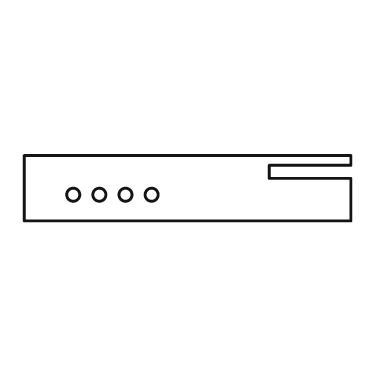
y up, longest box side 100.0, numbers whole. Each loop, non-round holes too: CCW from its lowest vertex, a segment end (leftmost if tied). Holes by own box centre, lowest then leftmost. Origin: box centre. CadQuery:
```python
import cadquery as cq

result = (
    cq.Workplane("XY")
    .moveTo(-50.0, -10.0)
    .lineTo(50.0, -10.0)
    .lineTo(50.0, 3.0)
    .lineTo(25.0, 3.0)
    .lineTo(25.0, 7.0)
    .lineTo(50.0, 7.0)
    .lineTo(50.0, 10.0)
    .lineTo(-50.0, 10.0)
    .close()
    .moveTo(-35.0, -2.0)
    .circle(2.0)
    .moveTo(-27.0, -2.0)
    .circle(2.0)
    .moveTo(-19.0, -2.0)
    .circle(2.0)
    .moveTo(-11.0, -2.0)
    .circle(2.0)
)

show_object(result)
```